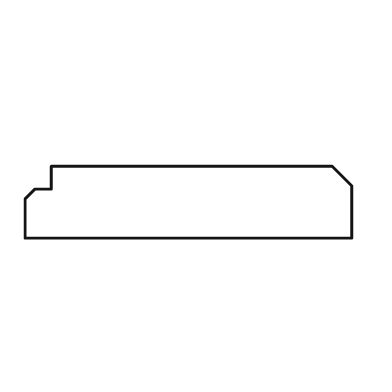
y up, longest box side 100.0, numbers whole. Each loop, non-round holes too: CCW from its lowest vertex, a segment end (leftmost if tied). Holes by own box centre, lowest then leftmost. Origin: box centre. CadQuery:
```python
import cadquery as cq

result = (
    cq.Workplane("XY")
    .moveTo(-50.0, -11.0)
    .lineTo(50.0, -11.0)
    .lineTo(50.0, 5.0)
    .lineTo(44.0, 11.0)
    .lineTo(-42.0, 11.0)
    .lineTo(-42.0, 4.0)
    .lineTo(-47.0, 4.0)
    .lineTo(-50.0, 1.0)
    .close()
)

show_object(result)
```